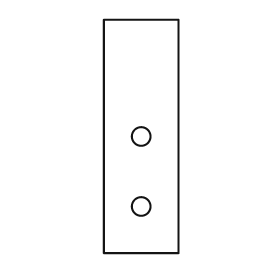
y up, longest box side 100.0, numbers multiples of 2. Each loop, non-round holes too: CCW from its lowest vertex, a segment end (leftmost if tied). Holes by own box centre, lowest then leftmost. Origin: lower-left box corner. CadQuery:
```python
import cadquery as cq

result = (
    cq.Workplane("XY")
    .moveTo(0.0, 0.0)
    .lineTo(32.0, 0.0)
    .lineTo(32.0, 100.0)
    .lineTo(0.0, 100.0)
    .close()
    .moveTo(16.0, 20.0)
    .circle(4.0)
    .moveTo(16.0, 50.0)
    .circle(4.0)
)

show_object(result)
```